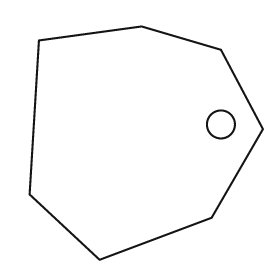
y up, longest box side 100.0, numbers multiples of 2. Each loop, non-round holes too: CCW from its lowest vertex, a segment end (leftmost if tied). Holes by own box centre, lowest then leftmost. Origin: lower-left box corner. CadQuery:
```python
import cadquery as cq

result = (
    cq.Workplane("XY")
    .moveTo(30.0, 0.0)
    .lineTo(78.0, 18.0)
    .lineTo(100.0, 56.0)
    .lineTo(82.0, 90.0)
    .lineTo(48.0, 100.0)
    .lineTo(4.0, 94.0)
    .lineTo(0.0, 28.0)
    .close()
    .moveTo(82.0, 58.0)
    .circle(6.0)
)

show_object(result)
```